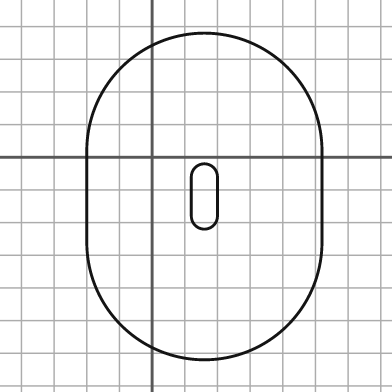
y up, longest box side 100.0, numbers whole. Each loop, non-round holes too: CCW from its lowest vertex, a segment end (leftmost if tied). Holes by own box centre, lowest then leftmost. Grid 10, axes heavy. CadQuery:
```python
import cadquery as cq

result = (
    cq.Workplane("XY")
    .moveTo(-20.0, -26.0)
    .threePointArc((16.0, -62.0), (52.0, -26.0))
    .lineTo(52.0, 2.0)
    .threePointArc((16.0, 38.0), (-20.0, 2.0))
    .close()
    .moveTo(12.0, -18.0)
    .threePointArc((16.0, -22.0), (20.0, -18.0))
    .lineTo(20.0, -6.0)
    .threePointArc((16.0, -2.0), (12.0, -6.0))
    .close()
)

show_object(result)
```